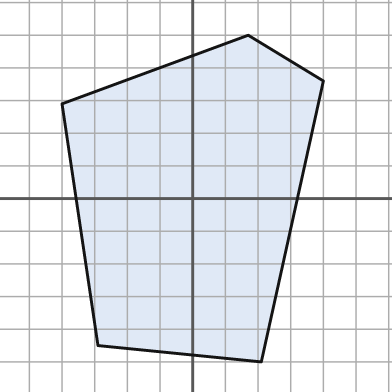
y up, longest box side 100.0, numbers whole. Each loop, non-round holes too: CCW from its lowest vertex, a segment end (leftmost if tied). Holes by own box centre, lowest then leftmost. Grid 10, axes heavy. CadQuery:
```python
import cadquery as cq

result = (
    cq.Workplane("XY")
    .moveTo(21.0, -50.0)
    .lineTo(40.0, 36.0)
    .lineTo(17.0, 50.0)
    .lineTo(-40.0, 29.0)
    .lineTo(-29.0, -45.0)
    .close()
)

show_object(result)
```